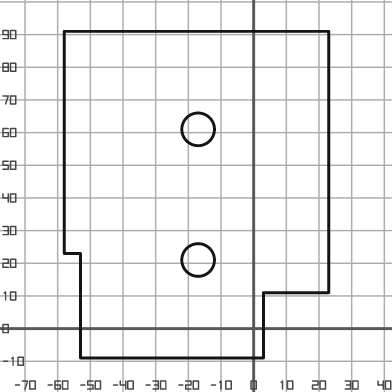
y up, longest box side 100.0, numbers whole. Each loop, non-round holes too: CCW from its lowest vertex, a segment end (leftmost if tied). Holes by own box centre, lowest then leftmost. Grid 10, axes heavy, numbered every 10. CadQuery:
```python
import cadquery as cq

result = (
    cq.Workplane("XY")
    .moveTo(-53.0, -9.0)
    .lineTo(3.0, -9.0)
    .lineTo(3.0, 11.0)
    .lineTo(23.0, 11.0)
    .lineTo(23.0, 91.0)
    .lineTo(-58.0, 91.0)
    .lineTo(-58.0, 23.0)
    .lineTo(-53.0, 23.0)
    .close()
    .moveTo(-17.0, 21.0)
    .circle(5.0)
    .moveTo(-17.0, 61.0)
    .circle(5.0)
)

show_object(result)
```